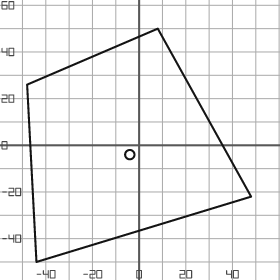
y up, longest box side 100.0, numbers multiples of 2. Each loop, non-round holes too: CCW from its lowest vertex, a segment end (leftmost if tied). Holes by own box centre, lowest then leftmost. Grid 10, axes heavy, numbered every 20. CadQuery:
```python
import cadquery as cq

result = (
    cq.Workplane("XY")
    .moveTo(-44.0, -50.0)
    .lineTo(48.0, -22.0)
    .lineTo(8.0, 50.0)
    .lineTo(-48.0, 26.0)
    .close()
    .moveTo(-4.0, -4.0)
    .circle(2.0)
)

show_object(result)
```